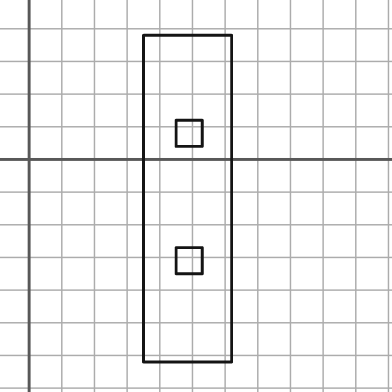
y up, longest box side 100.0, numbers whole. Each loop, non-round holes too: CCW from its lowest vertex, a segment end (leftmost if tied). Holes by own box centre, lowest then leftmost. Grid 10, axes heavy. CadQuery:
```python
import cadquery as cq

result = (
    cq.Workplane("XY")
    .moveTo(35.0, -62.0)
    .lineTo(62.0, -62.0)
    .lineTo(62.0, 38.0)
    .lineTo(35.0, 38.0)
    .close()
    .moveTo(45.0, -35.0)
    .lineTo(53.0, -35.0)
    .lineTo(53.0, -27.0)
    .lineTo(45.0, -27.0)
    .close()
    .moveTo(45.0, 4.0)
    .lineTo(53.0, 4.0)
    .lineTo(53.0, 12.0)
    .lineTo(45.0, 12.0)
    .close()
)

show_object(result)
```